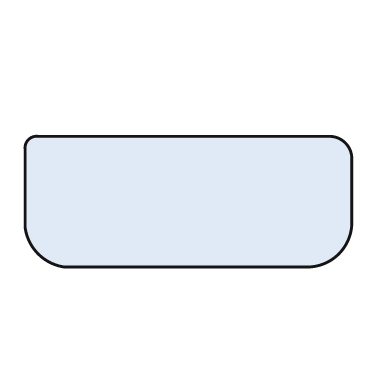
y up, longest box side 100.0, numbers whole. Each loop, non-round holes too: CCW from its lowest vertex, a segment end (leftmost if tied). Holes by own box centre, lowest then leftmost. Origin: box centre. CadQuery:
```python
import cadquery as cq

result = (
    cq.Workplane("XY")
    .moveTo(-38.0, -20.0)
    .lineTo(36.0, -20.0)
    .threePointArc((46.0, -16.0), (50.0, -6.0))
    .lineTo(50.0, 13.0)
    .threePointArc((48.0, 18.0), (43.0, 20.0))
    .lineTo(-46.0, 20.0)
    .threePointArc((-49.0, 19.0), (-50.0, 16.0))
    .lineTo(-50.0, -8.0)
    .threePointArc((-46.0, -16.0), (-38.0, -20.0))
    .close()
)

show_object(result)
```